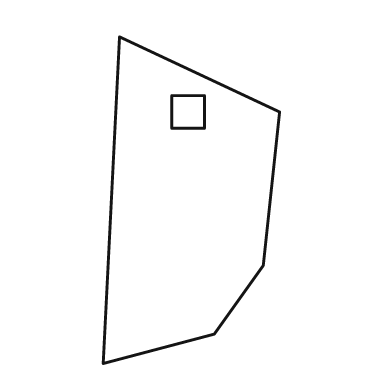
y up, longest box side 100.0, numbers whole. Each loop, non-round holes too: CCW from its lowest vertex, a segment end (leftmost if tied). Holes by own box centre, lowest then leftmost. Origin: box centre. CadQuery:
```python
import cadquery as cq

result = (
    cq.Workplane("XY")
    .moveTo(-27.0, -50.0)
    .lineTo(7.0, -41.0)
    .lineTo(22.0, -20.0)
    .lineTo(27.0, 27.0)
    .lineTo(-22.0, 50.0)
    .close()
    .moveTo(-6.0, 22.0)
    .lineTo(4.0, 22.0)
    .lineTo(4.0, 32.0)
    .lineTo(-6.0, 32.0)
    .close()
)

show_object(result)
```